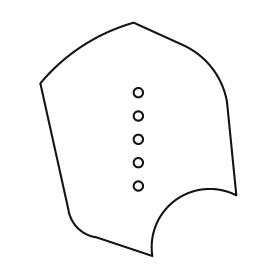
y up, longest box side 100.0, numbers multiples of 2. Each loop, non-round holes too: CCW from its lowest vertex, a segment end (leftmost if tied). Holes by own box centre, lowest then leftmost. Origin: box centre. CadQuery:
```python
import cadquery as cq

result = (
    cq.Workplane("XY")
    .moveTo(6.0, -50.0)
    .threePointArc((16.0, -26.0), (42.0, -24.0))
    .lineTo(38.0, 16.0)
    .threePointArc((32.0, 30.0), (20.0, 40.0))
    .lineTo(-2.0, 50.0)
    .threePointArc((-24.0, 40.0), (-42.0, 24.0))
    .lineTo(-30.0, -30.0)
    .threePointArc((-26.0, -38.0), (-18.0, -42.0))
    .close()
    .moveTo(0.0, -20.0)
    .circle(2.0)
    .moveTo(0.0, -10.0)
    .circle(2.0)
    .moveTo(0.0, 0.0)
    .circle(2.0)
    .moveTo(0.0, 10.0)
    .circle(2.0)
    .moveTo(0.0, 20.0)
    .circle(2.0)
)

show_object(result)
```